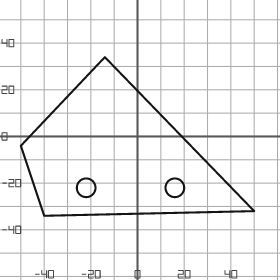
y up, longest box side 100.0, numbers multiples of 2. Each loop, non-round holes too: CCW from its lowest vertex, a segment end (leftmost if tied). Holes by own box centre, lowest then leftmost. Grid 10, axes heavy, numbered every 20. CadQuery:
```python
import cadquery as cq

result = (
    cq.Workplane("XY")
    .moveTo(-40.0, -34.0)
    .lineTo(50.0, -32.0)
    .lineTo(-14.0, 34.0)
    .lineTo(-50.0, -4.0)
    .close()
    .moveTo(-22.0, -22.0)
    .circle(4.0)
    .moveTo(16.0, -22.0)
    .circle(4.0)
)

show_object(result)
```